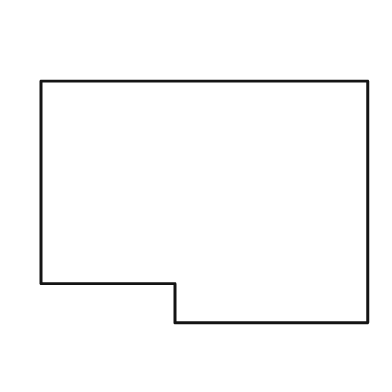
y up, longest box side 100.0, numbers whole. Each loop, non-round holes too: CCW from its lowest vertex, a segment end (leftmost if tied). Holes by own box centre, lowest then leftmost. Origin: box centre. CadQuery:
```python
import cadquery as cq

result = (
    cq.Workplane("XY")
    .moveTo(-9.0, -37.0)
    .lineTo(50.0, -37.0)
    .lineTo(50.0, 37.0)
    .lineTo(-50.0, 37.0)
    .lineTo(-50.0, -25.0)
    .lineTo(-9.0, -25.0)
    .close()
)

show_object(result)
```